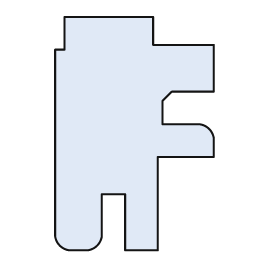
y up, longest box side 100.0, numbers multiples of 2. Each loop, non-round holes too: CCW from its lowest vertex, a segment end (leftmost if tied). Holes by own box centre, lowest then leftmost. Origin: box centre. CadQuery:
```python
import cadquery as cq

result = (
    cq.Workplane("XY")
    .moveTo(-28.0, -50.0)
    .lineTo(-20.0, -50.0)
    .threePointArc((-16.0, -48.0), (-14.0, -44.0))
    .lineTo(-14.0, -26.0)
    .lineTo(-4.0, -26.0)
    .lineTo(-4.0, -50.0)
    .lineTo(10.0, -50.0)
    .lineTo(10.0, -10.0)
    .lineTo(34.0, -10.0)
    .lineTo(34.0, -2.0)
    .threePointArc((32.0, 2.0), (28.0, 4.0))
    .lineTo(12.0, 4.0)
    .lineTo(12.0, 14.0)
    .lineTo(16.0, 18.0)
    .lineTo(34.0, 18.0)
    .lineTo(34.0, 38.0)
    .lineTo(8.0, 38.0)
    .lineTo(8.0, 50.0)
    .lineTo(-30.0, 50.0)
    .lineTo(-30.0, 36.0)
    .lineTo(-34.0, 36.0)
    .lineTo(-34.0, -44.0)
    .threePointArc((-32.0, -48.0), (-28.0, -50.0))
    .close()
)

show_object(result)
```